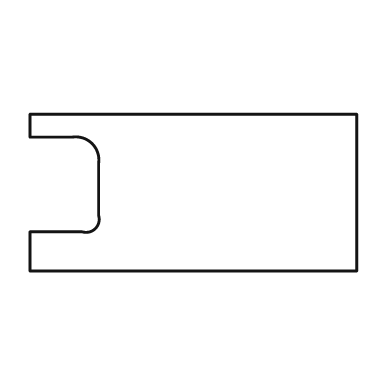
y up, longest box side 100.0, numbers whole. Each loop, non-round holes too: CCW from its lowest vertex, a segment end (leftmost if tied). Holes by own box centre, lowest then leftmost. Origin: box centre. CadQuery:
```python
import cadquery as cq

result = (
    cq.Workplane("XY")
    .moveTo(-50.0, -24.0)
    .lineTo(50.0, -24.0)
    .lineTo(50.0, 24.0)
    .lineTo(-50.0, 24.0)
    .lineTo(-50.0, 17.0)
    .lineTo(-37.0, 17.0)
    .threePointArc((-31.0, 15.0), (-29.0, 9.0))
    .lineTo(-29.0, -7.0)
    .threePointArc((-30.0, -11.0), (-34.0, -12.0))
    .lineTo(-50.0, -12.0)
    .close()
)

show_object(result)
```